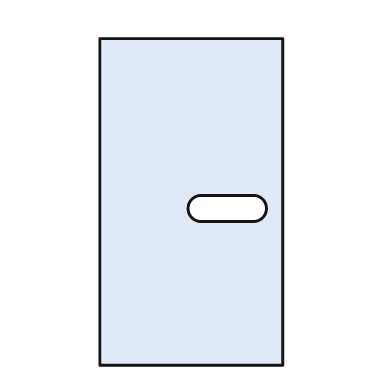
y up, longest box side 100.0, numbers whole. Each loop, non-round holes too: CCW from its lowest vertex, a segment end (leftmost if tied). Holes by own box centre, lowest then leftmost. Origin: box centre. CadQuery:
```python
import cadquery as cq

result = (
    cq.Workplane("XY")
    .moveTo(-28.0, -50.0)
    .lineTo(28.0, -50.0)
    .lineTo(28.0, 50.0)
    .lineTo(-28.0, 50.0)
    .close()
    .moveTo(3.0, -6.0)
    .lineTo(19.0, -6.0)
    .threePointArc((23.0, -2.0), (19.0, 2.0))
    .lineTo(3.0, 2.0)
    .threePointArc((-1.0, -2.0), (3.0, -6.0))
    .close()
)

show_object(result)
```